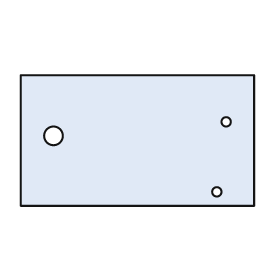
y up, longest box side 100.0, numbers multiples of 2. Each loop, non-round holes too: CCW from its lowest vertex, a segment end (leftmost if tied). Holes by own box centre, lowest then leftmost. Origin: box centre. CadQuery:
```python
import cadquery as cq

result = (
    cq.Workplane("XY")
    .moveTo(-50.0, -28.0)
    .lineTo(50.0, -28.0)
    .lineTo(50.0, 28.0)
    .lineTo(-50.0, 28.0)
    .close()
    .moveTo(34.0, -22.0)
    .circle(2.0)
    .moveTo(-36.0, 2.0)
    .circle(4.0)
    .moveTo(38.0, 8.0)
    .circle(2.0)
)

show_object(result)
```